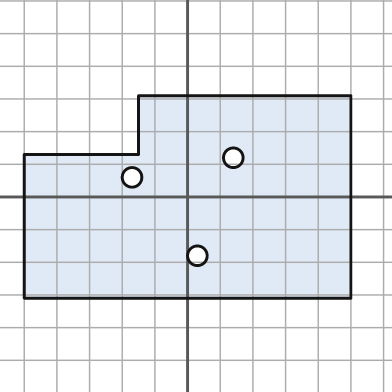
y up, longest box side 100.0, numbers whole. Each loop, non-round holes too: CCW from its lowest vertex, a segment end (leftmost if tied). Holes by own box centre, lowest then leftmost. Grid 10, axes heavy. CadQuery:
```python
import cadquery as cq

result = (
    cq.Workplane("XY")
    .moveTo(-50.0, -31.0)
    .lineTo(50.0, -31.0)
    .lineTo(50.0, 31.0)
    .lineTo(-15.0, 31.0)
    .lineTo(-15.0, 13.0)
    .lineTo(-50.0, 13.0)
    .close()
    .moveTo(3.0, -18.0)
    .circle(3.0)
    .moveTo(-17.0, 6.0)
    .circle(3.0)
    .moveTo(14.0, 12.0)
    .circle(3.0)
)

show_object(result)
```